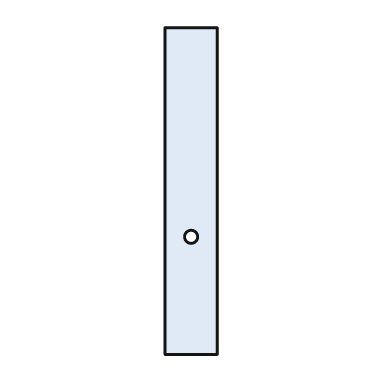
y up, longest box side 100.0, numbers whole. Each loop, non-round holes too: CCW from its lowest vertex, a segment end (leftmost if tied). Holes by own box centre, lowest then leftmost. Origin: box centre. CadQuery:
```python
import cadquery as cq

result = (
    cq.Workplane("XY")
    .moveTo(-8.0, -50.0)
    .lineTo(8.0, -50.0)
    .lineTo(8.0, 50.0)
    .lineTo(-8.0, 50.0)
    .close()
    .moveTo(0.0, -14.0)
    .circle(2.0)
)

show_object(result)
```